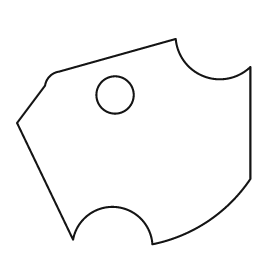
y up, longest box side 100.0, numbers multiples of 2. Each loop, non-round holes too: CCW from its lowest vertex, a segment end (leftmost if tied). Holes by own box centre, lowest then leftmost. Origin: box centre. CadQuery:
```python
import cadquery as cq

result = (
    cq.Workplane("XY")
    .moveTo(8.0, -44.0)
    .threePointArc((32.0, -34.0), (50.0, -16.0))
    .lineTo(50.0, 32.0)
    .threePointArc((30.0, 28.0), (18.0, 44.0))
    .lineTo(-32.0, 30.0)
    .threePointArc((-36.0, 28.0), (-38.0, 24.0))
    .lineTo(-50.0, 8.0)
    .lineTo(-26.0, -42.0)
    .threePointArc((-8.0, -28.0), (8.0, -44.0))
    .close()
    .moveTo(-8.0, 20.0)
    .circle(8.0)
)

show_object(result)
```